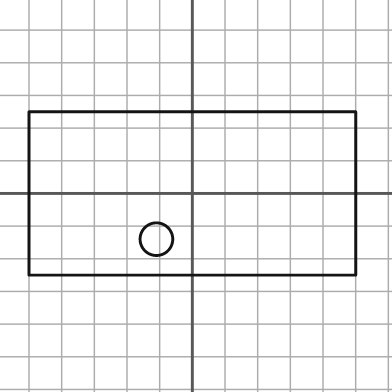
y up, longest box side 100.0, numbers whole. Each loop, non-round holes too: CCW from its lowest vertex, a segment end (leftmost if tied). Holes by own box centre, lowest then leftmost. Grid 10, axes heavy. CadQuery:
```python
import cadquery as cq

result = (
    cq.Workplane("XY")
    .moveTo(-50.0, -25.0)
    .lineTo(50.0, -25.0)
    .lineTo(50.0, 25.0)
    .lineTo(-50.0, 25.0)
    .close()
    .moveTo(-11.0, -14.0)
    .circle(5.0)
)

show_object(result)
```